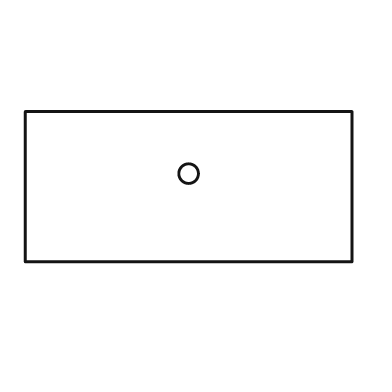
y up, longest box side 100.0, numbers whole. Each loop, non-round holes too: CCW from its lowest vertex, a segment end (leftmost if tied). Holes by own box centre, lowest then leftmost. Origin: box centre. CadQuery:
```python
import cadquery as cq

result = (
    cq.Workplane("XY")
    .moveTo(-50.0, -23.0)
    .lineTo(50.0, -23.0)
    .lineTo(50.0, 23.0)
    .lineTo(-50.0, 23.0)
    .close()
    .moveTo(0.0, 4.0)
    .circle(3.0)
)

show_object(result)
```